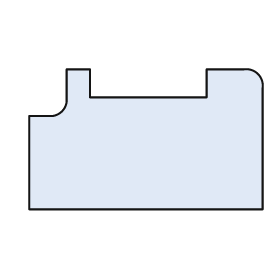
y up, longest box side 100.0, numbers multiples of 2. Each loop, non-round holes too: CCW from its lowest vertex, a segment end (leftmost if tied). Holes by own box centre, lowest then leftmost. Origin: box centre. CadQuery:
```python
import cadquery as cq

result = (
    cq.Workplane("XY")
    .moveTo(-50.0, -30.0)
    .lineTo(50.0, -30.0)
    .lineTo(50.0, 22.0)
    .threePointArc((48.0, 28.0), (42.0, 30.0))
    .lineTo(26.0, 30.0)
    .lineTo(26.0, 18.0)
    .lineTo(-24.0, 18.0)
    .lineTo(-24.0, 30.0)
    .lineTo(-34.0, 30.0)
    .lineTo(-34.0, 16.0)
    .threePointArc((-36.0, 12.0), (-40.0, 10.0))
    .lineTo(-50.0, 10.0)
    .close()
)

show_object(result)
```